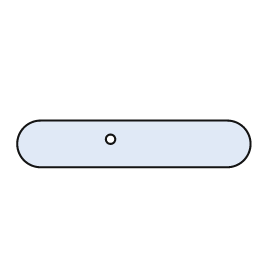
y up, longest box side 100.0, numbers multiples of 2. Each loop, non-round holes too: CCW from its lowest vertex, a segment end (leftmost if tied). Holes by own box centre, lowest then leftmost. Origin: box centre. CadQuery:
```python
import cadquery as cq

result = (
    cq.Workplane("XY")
    .moveTo(-40.0, -10.0)
    .lineTo(40.0, -10.0)
    .threePointArc((50.0, 0.0), (40.0, 10.0))
    .lineTo(-40.0, 10.0)
    .threePointArc((-50.0, 0.0), (-40.0, -10.0))
    .close()
    .moveTo(-10.0, 2.0)
    .circle(2.0)
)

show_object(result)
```